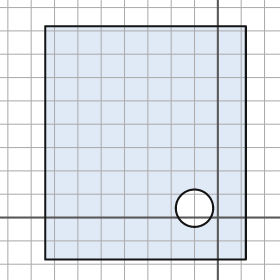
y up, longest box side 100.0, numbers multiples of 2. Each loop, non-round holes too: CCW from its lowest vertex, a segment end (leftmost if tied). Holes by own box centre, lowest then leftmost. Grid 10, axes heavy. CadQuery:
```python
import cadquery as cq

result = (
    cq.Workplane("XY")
    .moveTo(-74.0, -18.0)
    .lineTo(12.0, -18.0)
    .lineTo(12.0, 82.0)
    .lineTo(-74.0, 82.0)
    .close()
    .moveTo(-10.0, 4.0)
    .circle(8.0)
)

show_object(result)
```